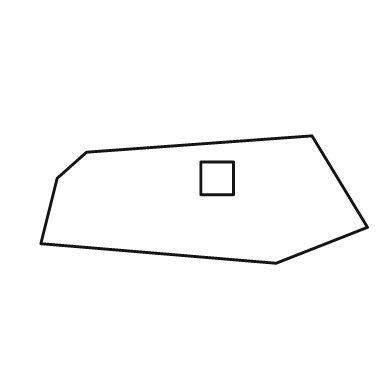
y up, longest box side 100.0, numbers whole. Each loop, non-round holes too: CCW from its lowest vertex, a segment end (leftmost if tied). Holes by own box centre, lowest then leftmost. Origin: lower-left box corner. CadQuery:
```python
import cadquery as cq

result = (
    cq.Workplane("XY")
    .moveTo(72.0, 0.0)
    .lineTo(100.0, 11.0)
    .lineTo(83.0, 39.0)
    .lineTo(14.0, 34.0)
    .lineTo(5.0, 26.0)
    .lineTo(0.0, 6.0)
    .close()
    .moveTo(49.0, 21.0)
    .lineTo(59.0, 21.0)
    .lineTo(59.0, 31.0)
    .lineTo(49.0, 31.0)
    .close()
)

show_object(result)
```